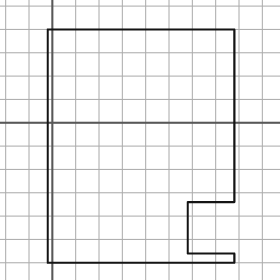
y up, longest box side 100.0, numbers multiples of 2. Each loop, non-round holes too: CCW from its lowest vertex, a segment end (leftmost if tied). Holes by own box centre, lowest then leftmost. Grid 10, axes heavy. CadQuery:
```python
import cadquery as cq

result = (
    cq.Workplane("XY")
    .moveTo(-2.0, -60.0)
    .lineTo(78.0, -60.0)
    .lineTo(78.0, -56.0)
    .lineTo(58.0, -56.0)
    .lineTo(58.0, -34.0)
    .lineTo(78.0, -34.0)
    .lineTo(78.0, 40.0)
    .lineTo(-2.0, 40.0)
    .close()
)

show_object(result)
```